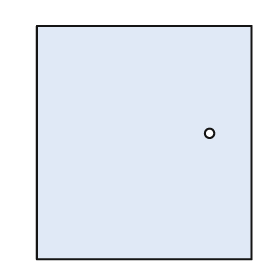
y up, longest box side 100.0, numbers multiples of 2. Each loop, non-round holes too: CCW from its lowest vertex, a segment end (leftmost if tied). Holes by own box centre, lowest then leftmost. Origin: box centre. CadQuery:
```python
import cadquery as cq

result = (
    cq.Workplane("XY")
    .moveTo(-46.0, -50.0)
    .lineTo(46.0, -50.0)
    .lineTo(46.0, 50.0)
    .lineTo(-46.0, 50.0)
    .close()
    .moveTo(28.0, 4.0)
    .circle(2.0)
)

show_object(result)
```